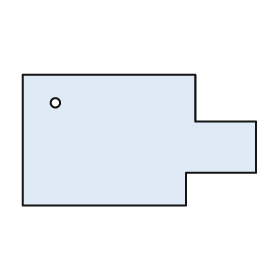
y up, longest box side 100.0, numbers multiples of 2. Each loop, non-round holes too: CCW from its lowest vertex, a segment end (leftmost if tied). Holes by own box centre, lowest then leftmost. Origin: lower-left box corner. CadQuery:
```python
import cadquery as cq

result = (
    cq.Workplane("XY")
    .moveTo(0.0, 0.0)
    .lineTo(70.0, 0.0)
    .lineTo(70.0, 14.0)
    .lineTo(100.0, 14.0)
    .lineTo(100.0, 36.0)
    .lineTo(74.0, 36.0)
    .lineTo(74.0, 56.0)
    .lineTo(0.0, 56.0)
    .close()
    .moveTo(14.0, 44.0)
    .circle(2.0)
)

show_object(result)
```